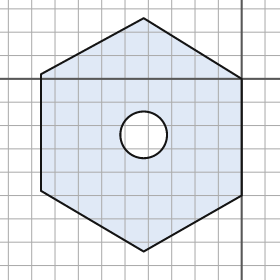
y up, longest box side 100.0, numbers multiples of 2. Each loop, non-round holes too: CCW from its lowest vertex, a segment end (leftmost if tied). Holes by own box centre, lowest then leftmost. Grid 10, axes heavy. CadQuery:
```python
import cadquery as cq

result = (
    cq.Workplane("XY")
    .moveTo(-42.0, -74.0)
    .lineTo(0.0, -50.0)
    .lineTo(0.0, 0.0)
    .lineTo(-42.0, 26.0)
    .lineTo(-86.0, 2.0)
    .lineTo(-86.0, -48.0)
    .close()
    .moveTo(-42.0, -24.0)
    .circle(10.0)
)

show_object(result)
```